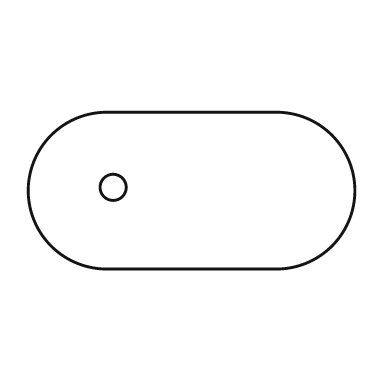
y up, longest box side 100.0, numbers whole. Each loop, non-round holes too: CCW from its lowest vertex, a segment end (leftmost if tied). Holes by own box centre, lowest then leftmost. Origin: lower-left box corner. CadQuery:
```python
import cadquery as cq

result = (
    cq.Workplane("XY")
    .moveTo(24.0, 0.0)
    .lineTo(76.0, 0.0)
    .threePointArc((100.0, 24.0), (76.0, 48.0))
    .lineTo(24.0, 48.0)
    .threePointArc((0.0, 24.0), (24.0, 0.0))
    .close()
    .moveTo(26.0, 25.0)
    .circle(4.0)
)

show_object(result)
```